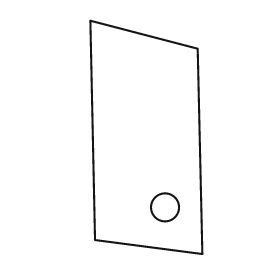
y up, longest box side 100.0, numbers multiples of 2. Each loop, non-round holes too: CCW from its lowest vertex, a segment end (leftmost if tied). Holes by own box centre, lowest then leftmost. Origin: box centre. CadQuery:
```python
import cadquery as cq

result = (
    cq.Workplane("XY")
    .moveTo(24.0, -50.0)
    .lineTo(22.0, 38.0)
    .lineTo(-24.0, 50.0)
    .lineTo(-22.0, -44.0)
    .close()
    .moveTo(8.0, -30.0)
    .circle(6.0)
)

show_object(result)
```